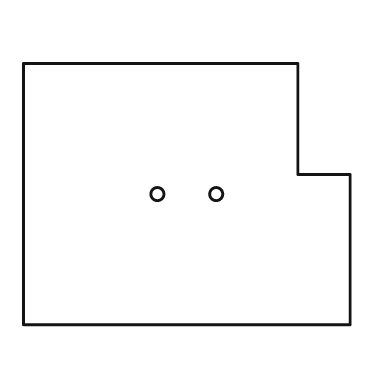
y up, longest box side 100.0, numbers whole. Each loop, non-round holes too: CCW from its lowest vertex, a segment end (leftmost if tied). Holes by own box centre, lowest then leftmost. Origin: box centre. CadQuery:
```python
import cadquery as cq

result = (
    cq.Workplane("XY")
    .moveTo(-50.0, -40.0)
    .lineTo(50.0, -40.0)
    .lineTo(50.0, 6.0)
    .lineTo(34.0, 6.0)
    .lineTo(34.0, 40.0)
    .lineTo(-50.0, 40.0)
    .close()
    .moveTo(-9.0, 0.0)
    .circle(2.0)
    .moveTo(9.0, 0.0)
    .circle(2.0)
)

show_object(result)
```